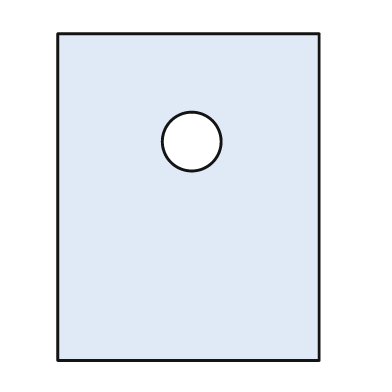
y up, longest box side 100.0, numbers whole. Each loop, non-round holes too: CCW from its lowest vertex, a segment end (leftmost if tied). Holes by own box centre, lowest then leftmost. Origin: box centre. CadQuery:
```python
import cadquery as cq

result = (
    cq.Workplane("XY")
    .moveTo(-40.0, -50.0)
    .lineTo(40.0, -50.0)
    .lineTo(40.0, 50.0)
    .lineTo(-40.0, 50.0)
    .close()
    .moveTo(1.0, 17.0)
    .circle(9.0)
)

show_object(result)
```